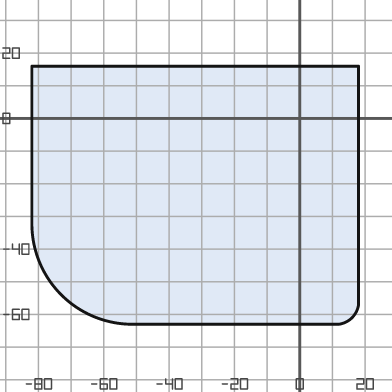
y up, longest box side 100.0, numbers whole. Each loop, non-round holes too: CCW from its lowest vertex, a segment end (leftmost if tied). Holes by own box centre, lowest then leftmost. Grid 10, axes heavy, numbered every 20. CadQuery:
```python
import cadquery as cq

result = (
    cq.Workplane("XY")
    .moveTo(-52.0, -63.0)
    .lineTo(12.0, -63.0)
    .threePointArc((16.0, -61.0), (18.0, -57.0))
    .lineTo(18.0, 16.0)
    .lineTo(-82.0, 16.0)
    .lineTo(-82.0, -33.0)
    .threePointArc((-73.0, -54.0), (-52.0, -63.0))
    .close()
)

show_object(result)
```